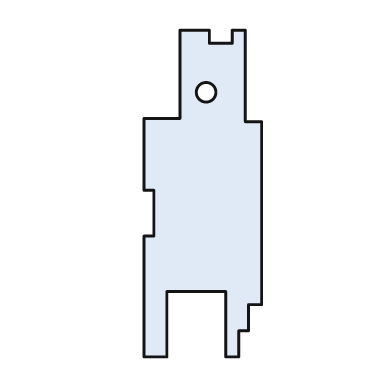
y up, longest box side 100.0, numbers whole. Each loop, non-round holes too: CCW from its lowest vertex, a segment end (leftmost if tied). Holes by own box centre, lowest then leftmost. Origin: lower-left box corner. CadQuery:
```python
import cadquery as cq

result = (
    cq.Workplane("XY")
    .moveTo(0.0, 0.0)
    .lineTo(7.0, 0.0)
    .lineTo(7.0, 20.0)
    .lineTo(25.0, 20.0)
    .lineTo(25.0, 0.0)
    .lineTo(29.0, 0.0)
    .lineTo(29.0, 8.0)
    .lineTo(32.0, 8.0)
    .lineTo(32.0, 16.0)
    .lineTo(36.0, 16.0)
    .lineTo(36.0, 72.0)
    .lineTo(31.0, 72.0)
    .lineTo(31.0, 100.0)
    .lineTo(27.0, 100.0)
    .lineTo(27.0, 96.0)
    .lineTo(20.0, 96.0)
    .lineTo(20.0, 100.0)
    .lineTo(11.0, 100.0)
    .lineTo(11.0, 73.0)
    .lineTo(0.0, 73.0)
    .lineTo(0.0, 51.0)
    .lineTo(3.0, 51.0)
    .lineTo(3.0, 37.0)
    .lineTo(0.0, 37.0)
    .close()
    .moveTo(19.0, 81.0)
    .circle(3.0)
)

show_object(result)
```